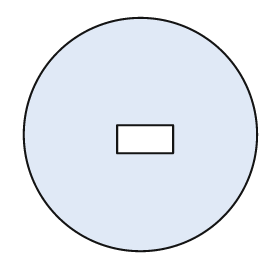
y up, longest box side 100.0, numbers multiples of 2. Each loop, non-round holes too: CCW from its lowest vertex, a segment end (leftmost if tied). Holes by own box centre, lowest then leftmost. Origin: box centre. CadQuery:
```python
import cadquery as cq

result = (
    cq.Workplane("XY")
    .moveTo(0.0, 0.0)
    .circle(50.0)
    .moveTo(-10.0, -8.0)
    .lineTo(14.0, -8.0)
    .lineTo(14.0, 4.0)
    .lineTo(-10.0, 4.0)
    .close()
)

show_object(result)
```